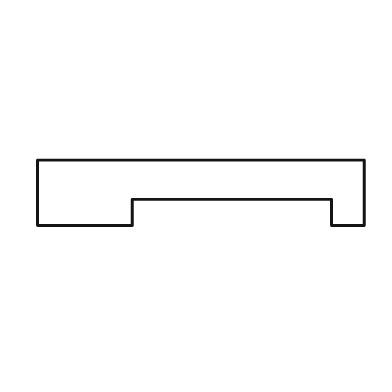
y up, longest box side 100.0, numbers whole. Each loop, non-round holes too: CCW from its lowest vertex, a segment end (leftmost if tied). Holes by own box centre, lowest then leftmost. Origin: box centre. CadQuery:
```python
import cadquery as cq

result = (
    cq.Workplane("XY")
    .moveTo(-50.0, -10.0)
    .lineTo(-21.0, -10.0)
    .lineTo(-21.0, -2.0)
    .lineTo(40.0, -2.0)
    .lineTo(40.0, -10.0)
    .lineTo(50.0, -10.0)
    .lineTo(50.0, 10.0)
    .lineTo(-50.0, 10.0)
    .close()
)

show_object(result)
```